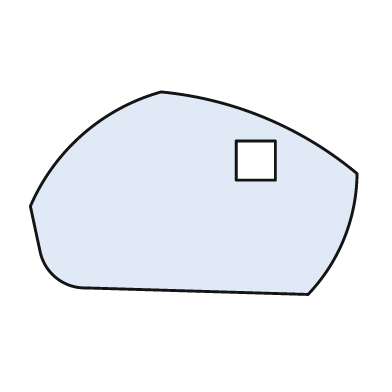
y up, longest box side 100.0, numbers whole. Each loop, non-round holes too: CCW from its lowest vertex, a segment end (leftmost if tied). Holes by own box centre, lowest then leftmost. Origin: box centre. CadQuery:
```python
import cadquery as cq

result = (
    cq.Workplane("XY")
    .moveTo(35.0, -31.0)
    .threePointArc((46.0, -14.0), (50.0, 6.0))
    .threePointArc((22.0, 23.0), (-10.0, 31.0))
    .threePointArc((-34.0, 18.0), (-50.0, -4.0))
    .lineTo(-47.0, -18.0)
    .threePointArc((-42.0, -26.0), (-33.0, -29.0))
    .close()
    .moveTo(13.0, 4.0)
    .lineTo(25.0, 4.0)
    .lineTo(25.0, 16.0)
    .lineTo(13.0, 16.0)
    .close()
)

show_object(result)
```